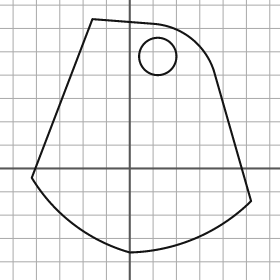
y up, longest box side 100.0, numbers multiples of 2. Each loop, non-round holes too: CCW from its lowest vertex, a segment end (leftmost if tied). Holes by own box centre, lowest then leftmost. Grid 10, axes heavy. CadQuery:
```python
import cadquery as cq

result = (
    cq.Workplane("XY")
    .moveTo(0.0, -36.0)
    .threePointArc((28.0, -30.0), (52.0, -14.0))
    .lineTo(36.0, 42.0)
    .threePointArc((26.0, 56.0), (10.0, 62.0))
    .lineTo(-16.0, 64.0)
    .lineTo(-42.0, -4.0)
    .threePointArc((-24.0, -24.0), (0.0, -36.0))
    .close()
    .moveTo(12.0, 48.0)
    .circle(8.0)
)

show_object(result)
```